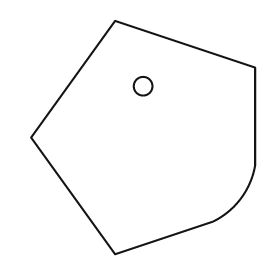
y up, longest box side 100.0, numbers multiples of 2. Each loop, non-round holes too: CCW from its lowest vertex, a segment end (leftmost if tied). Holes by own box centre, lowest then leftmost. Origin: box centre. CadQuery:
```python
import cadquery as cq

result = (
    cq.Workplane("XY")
    .moveTo(-12.0, -50.0)
    .lineTo(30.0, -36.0)
    .threePointArc((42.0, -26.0), (48.0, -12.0))
    .lineTo(48.0, 30.0)
    .lineTo(-12.0, 50.0)
    .lineTo(-48.0, 0.0)
    .close()
    .moveTo(0.0, 22.0)
    .circle(4.0)
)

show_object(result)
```